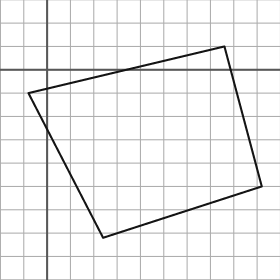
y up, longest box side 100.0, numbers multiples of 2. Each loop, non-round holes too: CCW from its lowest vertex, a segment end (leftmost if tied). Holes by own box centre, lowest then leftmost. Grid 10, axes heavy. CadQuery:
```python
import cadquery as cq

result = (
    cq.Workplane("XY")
    .moveTo(24.0, -72.0)
    .lineTo(92.0, -50.0)
    .lineTo(76.0, 10.0)
    .lineTo(-8.0, -10.0)
    .close()
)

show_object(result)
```